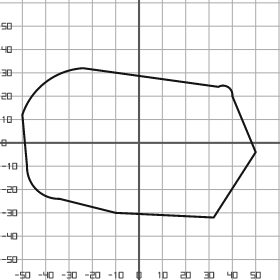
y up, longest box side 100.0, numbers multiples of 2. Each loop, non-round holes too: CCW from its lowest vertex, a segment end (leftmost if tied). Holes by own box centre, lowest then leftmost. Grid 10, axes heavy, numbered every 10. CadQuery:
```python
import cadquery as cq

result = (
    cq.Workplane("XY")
    .moveTo(32.0, -32.0)
    .lineTo(50.0, -4.0)
    .lineTo(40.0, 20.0)
    .threePointArc((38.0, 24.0), (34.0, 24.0))
    .lineTo(-24.0, 32.0)
    .threePointArc((-40.0, 26.0), (-50.0, 12.0))
    .lineTo(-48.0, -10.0)
    .threePointArc((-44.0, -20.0), (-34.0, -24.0))
    .lineTo(-10.0, -30.0)
    .close()
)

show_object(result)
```